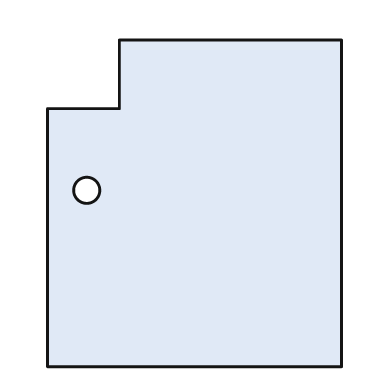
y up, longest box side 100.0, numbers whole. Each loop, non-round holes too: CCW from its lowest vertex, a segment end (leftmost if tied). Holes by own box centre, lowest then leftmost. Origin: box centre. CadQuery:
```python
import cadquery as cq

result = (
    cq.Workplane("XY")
    .moveTo(-45.0, -50.0)
    .lineTo(45.0, -50.0)
    .lineTo(45.0, 50.0)
    .lineTo(-23.0, 50.0)
    .lineTo(-23.0, 29.0)
    .lineTo(-45.0, 29.0)
    .close()
    .moveTo(-33.0, 4.0)
    .circle(4.0)
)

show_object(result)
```